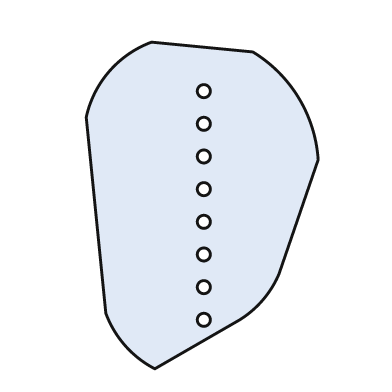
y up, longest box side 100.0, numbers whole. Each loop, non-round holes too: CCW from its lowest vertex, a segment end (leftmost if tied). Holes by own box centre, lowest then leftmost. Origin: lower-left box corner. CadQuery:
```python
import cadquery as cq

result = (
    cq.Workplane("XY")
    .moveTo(21.0, 0.0)
    .lineTo(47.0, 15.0)
    .threePointArc((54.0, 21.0), (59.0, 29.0))
    .lineTo(71.0, 64.0)
    .threePointArc((65.0, 83.0), (51.0, 97.0))
    .lineTo(20.0, 100.0)
    .threePointArc((7.0, 91.0), (0.0, 77.0))
    .lineTo(6.0, 17.0)
    .threePointArc((12.0, 7.0), (21.0, 0.0))
    .close()
    .moveTo(36.0, 15.0)
    .circle(2.0)
    .moveTo(36.0, 25.0)
    .circle(2.0)
    .moveTo(36.0, 35.0)
    .circle(2.0)
    .moveTo(36.0, 45.0)
    .circle(2.0)
    .moveTo(36.0, 55.0)
    .circle(2.0)
    .moveTo(36.0, 65.0)
    .circle(2.0)
    .moveTo(36.0, 75.0)
    .circle(2.0)
    .moveTo(36.0, 85.0)
    .circle(2.0)
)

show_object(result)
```